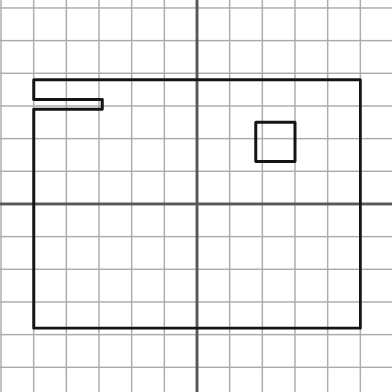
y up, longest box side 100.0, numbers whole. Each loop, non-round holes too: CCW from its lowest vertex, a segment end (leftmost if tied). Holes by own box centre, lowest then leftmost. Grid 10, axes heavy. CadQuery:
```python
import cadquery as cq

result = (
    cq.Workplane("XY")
    .moveTo(-50.0, -38.0)
    .lineTo(50.0, -38.0)
    .lineTo(50.0, 38.0)
    .lineTo(-50.0, 38.0)
    .lineTo(-50.0, 32.0)
    .lineTo(-29.0, 32.0)
    .lineTo(-29.0, 29.0)
    .lineTo(-50.0, 29.0)
    .close()
    .moveTo(18.0, 13.0)
    .lineTo(30.0, 13.0)
    .lineTo(30.0, 25.0)
    .lineTo(18.0, 25.0)
    .close()
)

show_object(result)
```